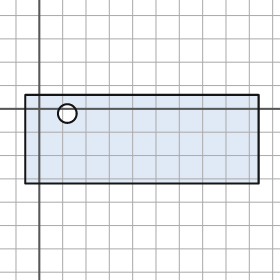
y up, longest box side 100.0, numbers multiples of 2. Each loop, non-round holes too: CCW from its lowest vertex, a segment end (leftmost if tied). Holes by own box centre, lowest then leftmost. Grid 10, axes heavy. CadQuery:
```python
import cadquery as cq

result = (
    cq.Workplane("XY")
    .moveTo(-6.0, -32.0)
    .lineTo(94.0, -32.0)
    .lineTo(94.0, 6.0)
    .lineTo(-6.0, 6.0)
    .close()
    .moveTo(12.0, -2.0)
    .circle(4.0)
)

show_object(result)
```